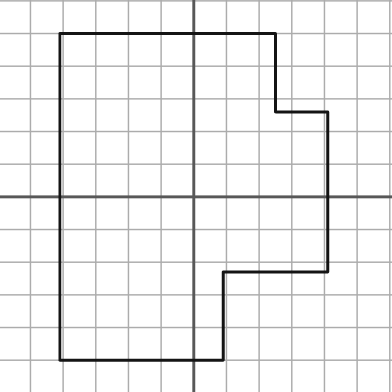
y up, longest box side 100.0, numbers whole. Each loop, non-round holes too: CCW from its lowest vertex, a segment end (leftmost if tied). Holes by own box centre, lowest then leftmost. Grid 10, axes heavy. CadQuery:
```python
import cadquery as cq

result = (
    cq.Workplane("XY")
    .moveTo(-41.0, -50.0)
    .lineTo(9.0, -50.0)
    .lineTo(9.0, -23.0)
    .lineTo(41.0, -23.0)
    .lineTo(41.0, 26.0)
    .lineTo(25.0, 26.0)
    .lineTo(25.0, 50.0)
    .lineTo(-41.0, 50.0)
    .close()
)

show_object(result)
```